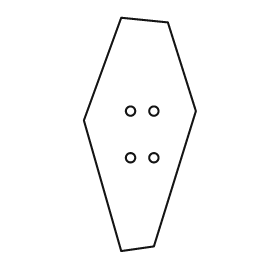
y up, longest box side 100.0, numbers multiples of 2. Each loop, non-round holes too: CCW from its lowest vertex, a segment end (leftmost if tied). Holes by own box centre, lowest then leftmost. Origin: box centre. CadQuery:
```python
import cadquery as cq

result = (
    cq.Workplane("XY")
    .moveTo(-8.0, -50.0)
    .lineTo(6.0, -48.0)
    .lineTo(24.0, 10.0)
    .lineTo(12.0, 48.0)
    .lineTo(-8.0, 50.0)
    .lineTo(-24.0, 6.0)
    .close()
    .moveTo(-4.0, -10.0)
    .circle(2.0)
    .moveTo(6.0, -10.0)
    .circle(2.0)
    .moveTo(-4.0, 10.0)
    .circle(2.0)
    .moveTo(6.0, 10.0)
    .circle(2.0)
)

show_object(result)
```